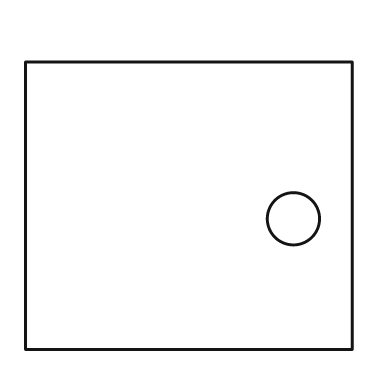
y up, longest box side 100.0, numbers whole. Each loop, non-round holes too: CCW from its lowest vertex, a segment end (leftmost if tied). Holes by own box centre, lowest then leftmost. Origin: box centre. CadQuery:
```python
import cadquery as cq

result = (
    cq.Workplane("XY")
    .moveTo(-50.0, -44.0)
    .lineTo(50.0, -44.0)
    .lineTo(50.0, 44.0)
    .lineTo(-50.0, 44.0)
    .close()
    .moveTo(32.0, -4.0)
    .circle(8.0)
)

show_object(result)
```